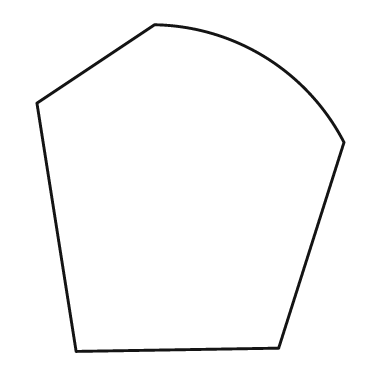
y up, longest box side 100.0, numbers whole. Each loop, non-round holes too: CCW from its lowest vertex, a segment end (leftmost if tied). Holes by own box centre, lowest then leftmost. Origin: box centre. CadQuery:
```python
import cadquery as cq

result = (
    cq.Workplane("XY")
    .moveTo(-35.0, -50.0)
    .lineTo(27.0, -49.0)
    .lineTo(47.0, 14.0)
    .threePointArc((23.0, 40.0), (-11.0, 50.0))
    .lineTo(-47.0, 26.0)
    .close()
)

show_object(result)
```